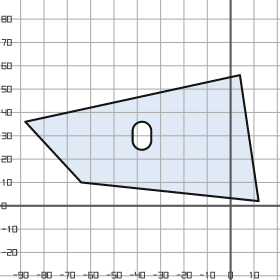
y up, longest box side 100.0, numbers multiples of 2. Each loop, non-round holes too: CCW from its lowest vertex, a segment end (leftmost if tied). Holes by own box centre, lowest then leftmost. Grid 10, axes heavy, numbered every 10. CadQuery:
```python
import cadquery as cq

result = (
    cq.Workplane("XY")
    .moveTo(12.0, 2.0)
    .lineTo(4.0, 56.0)
    .lineTo(-88.0, 36.0)
    .lineTo(-64.0, 10.0)
    .close()
    .moveTo(-42.0, 28.0)
    .threePointArc((-38.0, 24.0), (-34.0, 28.0))
    .lineTo(-34.0, 32.0)
    .threePointArc((-38.0, 36.0), (-42.0, 32.0))
    .close()
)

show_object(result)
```